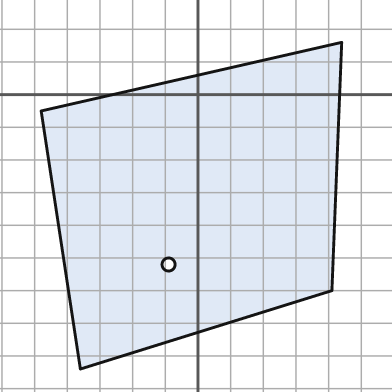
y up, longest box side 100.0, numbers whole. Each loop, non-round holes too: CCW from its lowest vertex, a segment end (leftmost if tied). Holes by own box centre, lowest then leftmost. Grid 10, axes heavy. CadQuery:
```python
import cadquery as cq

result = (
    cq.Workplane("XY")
    .moveTo(-36.0, -84.0)
    .lineTo(41.0, -60.0)
    .lineTo(44.0, 16.0)
    .lineTo(-48.0, -5.0)
    .close()
    .moveTo(-9.0, -52.0)
    .circle(2.0)
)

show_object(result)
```